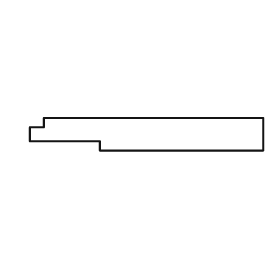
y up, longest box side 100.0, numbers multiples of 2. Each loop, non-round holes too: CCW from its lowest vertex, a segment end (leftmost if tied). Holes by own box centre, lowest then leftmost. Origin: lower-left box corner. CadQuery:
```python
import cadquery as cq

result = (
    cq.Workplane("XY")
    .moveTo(30.0, 0.0)
    .lineTo(100.0, 0.0)
    .lineTo(100.0, 14.0)
    .lineTo(6.0, 14.0)
    .lineTo(6.0, 10.0)
    .lineTo(0.0, 10.0)
    .lineTo(0.0, 4.0)
    .lineTo(30.0, 4.0)
    .close()
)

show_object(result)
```